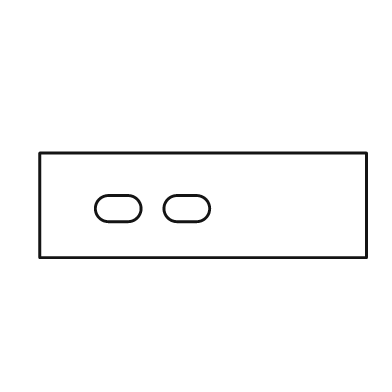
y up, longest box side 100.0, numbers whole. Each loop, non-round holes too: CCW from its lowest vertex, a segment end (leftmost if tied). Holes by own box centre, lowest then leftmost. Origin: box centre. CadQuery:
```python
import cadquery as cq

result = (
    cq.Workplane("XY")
    .moveTo(-50.0, -16.0)
    .lineTo(50.0, -16.0)
    .lineTo(50.0, 16.0)
    .lineTo(-50.0, 16.0)
    .close()
    .moveTo(-29.0, -5.0)
    .lineTo(-23.0, -5.0)
    .threePointArc((-19.0, -1.0), (-23.0, 3.0))
    .lineTo(-29.0, 3.0)
    .threePointArc((-33.0, -1.0), (-29.0, -5.0))
    .close()
    .moveTo(-8.0, -5.0)
    .lineTo(-2.0, -5.0)
    .threePointArc((2.0, -1.0), (-2.0, 3.0))
    .lineTo(-8.0, 3.0)
    .threePointArc((-12.0, -1.0), (-8.0, -5.0))
    .close()
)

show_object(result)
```